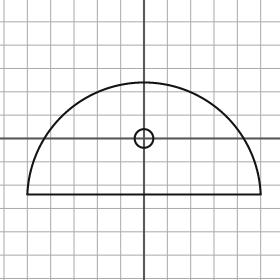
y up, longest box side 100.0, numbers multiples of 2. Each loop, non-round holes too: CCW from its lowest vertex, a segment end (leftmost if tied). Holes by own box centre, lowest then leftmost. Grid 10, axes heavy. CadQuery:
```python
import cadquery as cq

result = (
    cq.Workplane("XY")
    .moveTo(-50.0, -24.0)
    .lineTo(50.0, -24.0)
    .threePointArc((0.0, 24.0), (-50.0, -24.0))
    .close()
    .moveTo(0.0, 0.0)
    .circle(4.0)
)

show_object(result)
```